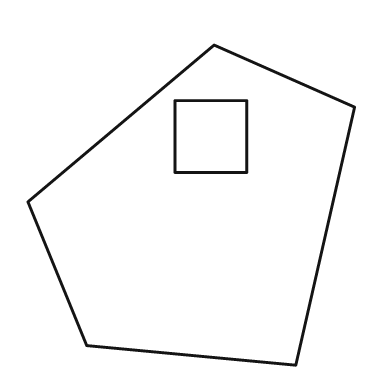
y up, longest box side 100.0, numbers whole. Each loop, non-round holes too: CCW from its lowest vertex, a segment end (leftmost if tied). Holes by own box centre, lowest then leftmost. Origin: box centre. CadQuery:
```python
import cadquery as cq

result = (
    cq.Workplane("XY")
    .moveTo(32.0, -49.0)
    .lineTo(50.0, 30.0)
    .lineTo(7.0, 49.0)
    .lineTo(-50.0, 1.0)
    .lineTo(-32.0, -43.0)
    .close()
    .moveTo(-5.0, 10.0)
    .lineTo(17.0, 10.0)
    .lineTo(17.0, 32.0)
    .lineTo(-5.0, 32.0)
    .close()
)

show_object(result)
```